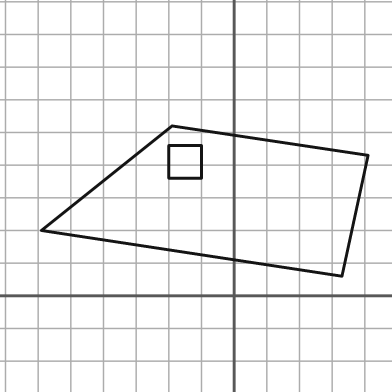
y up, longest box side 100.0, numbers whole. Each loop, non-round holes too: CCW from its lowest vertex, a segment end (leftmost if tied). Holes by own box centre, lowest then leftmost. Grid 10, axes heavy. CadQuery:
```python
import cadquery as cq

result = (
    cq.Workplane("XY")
    .moveTo(33.0, 6.0)
    .lineTo(41.0, 43.0)
    .lineTo(-19.0, 52.0)
    .lineTo(-59.0, 20.0)
    .close()
    .moveTo(-20.0, 36.0)
    .lineTo(-10.0, 36.0)
    .lineTo(-10.0, 46.0)
    .lineTo(-20.0, 46.0)
    .close()
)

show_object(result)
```